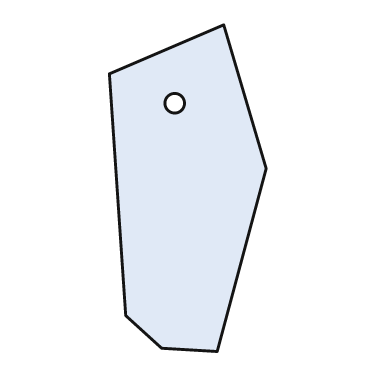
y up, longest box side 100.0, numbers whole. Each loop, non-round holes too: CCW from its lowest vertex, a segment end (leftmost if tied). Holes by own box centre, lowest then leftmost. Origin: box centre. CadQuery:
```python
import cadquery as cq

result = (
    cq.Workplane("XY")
    .moveTo(9.0, -50.0)
    .lineTo(24.0, 6.0)
    .lineTo(11.0, 50.0)
    .lineTo(-24.0, 35.0)
    .lineTo(-19.0, -39.0)
    .lineTo(-8.0, -49.0)
    .close()
    .moveTo(-4.0, 26.0)
    .circle(3.0)
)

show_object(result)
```